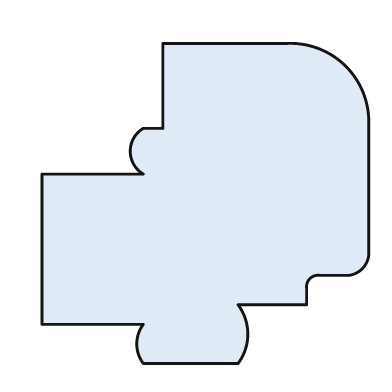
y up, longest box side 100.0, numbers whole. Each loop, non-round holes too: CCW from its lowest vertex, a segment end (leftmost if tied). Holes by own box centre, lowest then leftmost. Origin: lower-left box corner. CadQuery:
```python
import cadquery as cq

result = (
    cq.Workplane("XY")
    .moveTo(31.0, 0.0)
    .lineTo(60.0, 0.0)
    .threePointArc((63.0, 9.0), (60.0, 18.0))
    .lineTo(81.0, 18.0)
    .lineTo(81.0, 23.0)
    .threePointArc((82.0, 26.0), (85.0, 27.0))
    .lineTo(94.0, 27.0)
    .threePointArc((98.0, 29.0), (100.0, 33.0))
    .lineTo(100.0, 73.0)
    .threePointArc((93.0, 91.0), (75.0, 98.0))
    .lineTo(37.0, 98.0)
    .lineTo(37.0, 72.0)
    .lineTo(31.0, 72.0)
    .threePointArc((27.0, 65.0), (31.0, 58.0))
    .lineTo(0.0, 58.0)
    .lineTo(0.0, 12.0)
    .lineTo(31.0, 12.0)
    .threePointArc((29.0, 6.0), (31.0, 0.0))
    .close()
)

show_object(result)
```